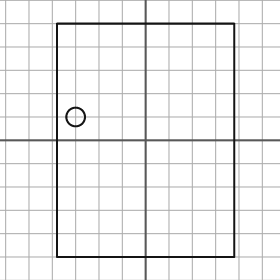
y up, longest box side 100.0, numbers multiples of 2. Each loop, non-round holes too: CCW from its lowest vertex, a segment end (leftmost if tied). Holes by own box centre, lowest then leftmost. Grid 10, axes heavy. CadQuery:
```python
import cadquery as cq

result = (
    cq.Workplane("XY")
    .moveTo(-38.0, -50.0)
    .lineTo(38.0, -50.0)
    .lineTo(38.0, 50.0)
    .lineTo(-38.0, 50.0)
    .close()
    .moveTo(-30.0, 10.0)
    .circle(4.0)
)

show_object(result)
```